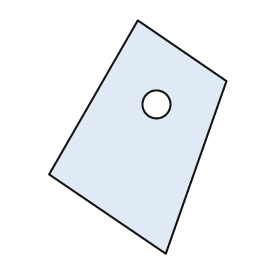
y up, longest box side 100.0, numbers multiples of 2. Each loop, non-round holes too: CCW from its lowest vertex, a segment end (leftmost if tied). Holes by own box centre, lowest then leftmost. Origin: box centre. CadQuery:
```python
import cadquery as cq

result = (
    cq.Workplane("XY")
    .moveTo(12.0, -50.0)
    .lineTo(38.0, 24.0)
    .lineTo(0.0, 50.0)
    .lineTo(-38.0, -16.0)
    .close()
    .moveTo(8.0, 14.0)
    .circle(6.0)
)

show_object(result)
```